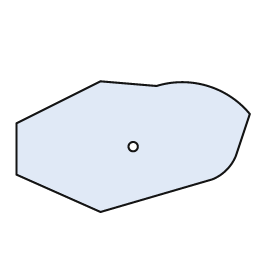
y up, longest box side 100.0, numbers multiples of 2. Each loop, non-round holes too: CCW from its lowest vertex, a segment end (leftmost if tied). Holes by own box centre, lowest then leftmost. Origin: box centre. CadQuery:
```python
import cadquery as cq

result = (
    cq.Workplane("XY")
    .moveTo(-14.0, -28.0)
    .lineTo(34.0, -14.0)
    .threePointArc((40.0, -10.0), (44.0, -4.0))
    .lineTo(50.0, 14.0)
    .threePointArc((32.0, 26.0), (10.0, 26.0))
    .lineTo(-14.0, 28.0)
    .lineTo(-50.0, 10.0)
    .lineTo(-50.0, -12.0)
    .close()
    .moveTo(0.0, 0.0)
    .circle(2.0)
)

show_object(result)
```